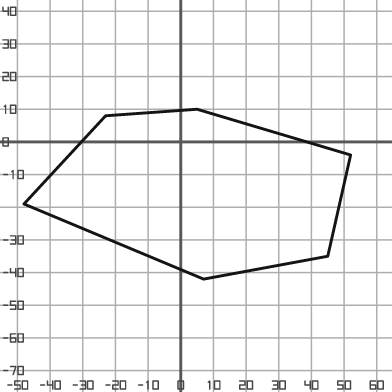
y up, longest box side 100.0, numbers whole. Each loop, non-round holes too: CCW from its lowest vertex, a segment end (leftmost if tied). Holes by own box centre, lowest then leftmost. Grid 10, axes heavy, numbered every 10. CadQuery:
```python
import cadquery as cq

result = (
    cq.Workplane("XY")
    .moveTo(7.0, -42.0)
    .lineTo(45.0, -35.0)
    .lineTo(52.0, -4.0)
    .lineTo(5.0, 10.0)
    .lineTo(-23.0, 8.0)
    .lineTo(-48.0, -19.0)
    .close()
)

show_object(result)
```